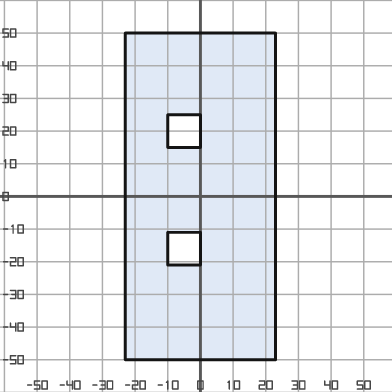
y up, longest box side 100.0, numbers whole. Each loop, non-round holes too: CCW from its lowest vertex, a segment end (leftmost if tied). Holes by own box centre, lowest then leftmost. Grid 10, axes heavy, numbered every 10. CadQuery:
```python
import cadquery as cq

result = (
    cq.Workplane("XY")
    .moveTo(-23.0, -50.0)
    .lineTo(23.0, -50.0)
    .lineTo(23.0, 50.0)
    .lineTo(-23.0, 50.0)
    .close()
    .moveTo(-10.0, -21.0)
    .lineTo(0.0, -21.0)
    .lineTo(0.0, -11.0)
    .lineTo(-10.0, -11.0)
    .close()
    .moveTo(-10.0, 15.0)
    .lineTo(0.0, 15.0)
    .lineTo(0.0, 25.0)
    .lineTo(-10.0, 25.0)
    .close()
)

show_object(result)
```